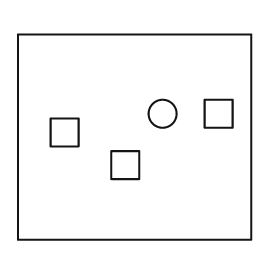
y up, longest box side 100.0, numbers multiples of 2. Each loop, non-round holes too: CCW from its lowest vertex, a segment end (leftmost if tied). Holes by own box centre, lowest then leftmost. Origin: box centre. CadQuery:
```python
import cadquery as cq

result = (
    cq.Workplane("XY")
    .moveTo(-50.0, -44.0)
    .lineTo(50.0, -44.0)
    .lineTo(50.0, 44.0)
    .lineTo(-50.0, 44.0)
    .close()
    .moveTo(-10.0, -18.0)
    .lineTo(2.0, -18.0)
    .lineTo(2.0, -6.0)
    .lineTo(-10.0, -6.0)
    .close()
    .moveTo(-36.0, -4.0)
    .lineTo(-24.0, -4.0)
    .lineTo(-24.0, 8.0)
    .lineTo(-36.0, 8.0)
    .close()
    .moveTo(12.0, 10.0)
    .circle(6.0)
    .moveTo(30.0, 4.0)
    .lineTo(42.0, 4.0)
    .lineTo(42.0, 16.0)
    .lineTo(30.0, 16.0)
    .close()
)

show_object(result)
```